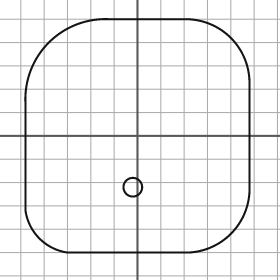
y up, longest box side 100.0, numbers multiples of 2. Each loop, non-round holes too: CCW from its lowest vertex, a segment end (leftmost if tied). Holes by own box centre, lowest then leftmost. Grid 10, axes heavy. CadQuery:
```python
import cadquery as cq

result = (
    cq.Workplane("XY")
    .moveTo(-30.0, -50.0)
    .lineTo(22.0, -50.0)
    .threePointArc((40.0, -42.0), (48.0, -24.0))
    .lineTo(48.0, 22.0)
    .threePointArc((40.0, 42.0), (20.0, 50.0))
    .lineTo(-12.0, 50.0)
    .threePointArc((-38.0, 40.0), (-48.0, 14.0))
    .lineTo(-48.0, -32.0)
    .threePointArc((-42.0, -44.0), (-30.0, -50.0))
    .close()
    .moveTo(-2.0, -22.0)
    .circle(4.0)
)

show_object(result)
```